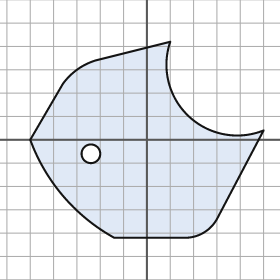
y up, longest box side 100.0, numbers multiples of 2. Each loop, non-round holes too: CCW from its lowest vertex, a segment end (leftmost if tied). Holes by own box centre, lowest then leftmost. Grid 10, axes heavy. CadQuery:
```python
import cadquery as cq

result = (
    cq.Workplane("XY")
    .moveTo(-14.0, -42.0)
    .lineTo(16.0, -42.0)
    .threePointArc((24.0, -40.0), (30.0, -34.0))
    .lineTo(50.0, 4.0)
    .threePointArc((18.0, 10.0), (10.0, 42.0))
    .lineTo(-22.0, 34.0)
    .threePointArc((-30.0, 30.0), (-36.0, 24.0))
    .lineTo(-50.0, 0.0)
    .threePointArc((-36.0, -24.0), (-14.0, -42.0))
    .close()
    .moveTo(-24.0, -6.0)
    .circle(4.0)
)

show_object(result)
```